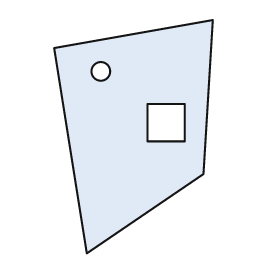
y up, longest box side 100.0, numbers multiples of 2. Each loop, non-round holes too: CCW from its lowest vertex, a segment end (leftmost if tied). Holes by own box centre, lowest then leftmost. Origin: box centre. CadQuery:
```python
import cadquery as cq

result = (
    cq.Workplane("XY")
    .moveTo(-20.0, -50.0)
    .lineTo(30.0, -16.0)
    .lineTo(34.0, 50.0)
    .lineTo(-34.0, 38.0)
    .close()
    .moveTo(6.0, -2.0)
    .lineTo(22.0, -2.0)
    .lineTo(22.0, 14.0)
    .lineTo(6.0, 14.0)
    .close()
    .moveTo(-14.0, 28.0)
    .circle(4.0)
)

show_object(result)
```